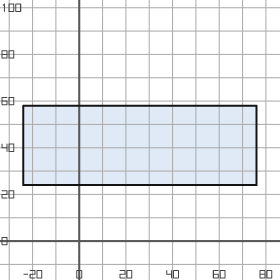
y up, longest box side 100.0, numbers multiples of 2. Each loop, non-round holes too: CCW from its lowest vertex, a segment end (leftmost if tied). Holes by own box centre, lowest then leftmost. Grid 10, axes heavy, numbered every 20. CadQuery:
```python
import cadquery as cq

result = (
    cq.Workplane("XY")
    .moveTo(-24.0, 24.0)
    .lineTo(76.0, 24.0)
    .lineTo(76.0, 58.0)
    .lineTo(-24.0, 58.0)
    .close()
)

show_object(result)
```